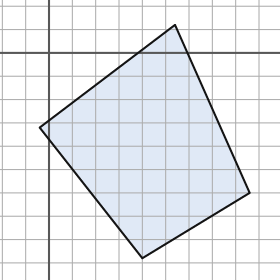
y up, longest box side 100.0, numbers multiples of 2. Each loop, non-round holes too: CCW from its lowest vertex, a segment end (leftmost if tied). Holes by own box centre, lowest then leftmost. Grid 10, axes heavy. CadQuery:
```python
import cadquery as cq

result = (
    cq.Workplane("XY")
    .moveTo(40.0, -88.0)
    .lineTo(86.0, -60.0)
    .lineTo(54.0, 12.0)
    .lineTo(-4.0, -32.0)
    .close()
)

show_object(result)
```